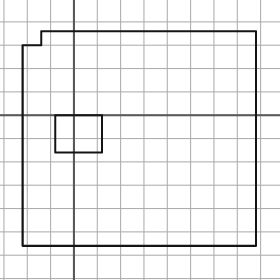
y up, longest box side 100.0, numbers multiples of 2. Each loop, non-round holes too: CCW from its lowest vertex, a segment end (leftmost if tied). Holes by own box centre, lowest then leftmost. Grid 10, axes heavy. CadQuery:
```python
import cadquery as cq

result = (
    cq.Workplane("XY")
    .moveTo(-22.0, -56.0)
    .lineTo(78.0, -56.0)
    .lineTo(78.0, 36.0)
    .lineTo(-14.0, 36.0)
    .lineTo(-14.0, 30.0)
    .lineTo(-22.0, 30.0)
    .close()
    .moveTo(-8.0, -16.0)
    .lineTo(12.0, -16.0)
    .lineTo(12.0, 0.0)
    .lineTo(-8.0, 0.0)
    .close()
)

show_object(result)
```